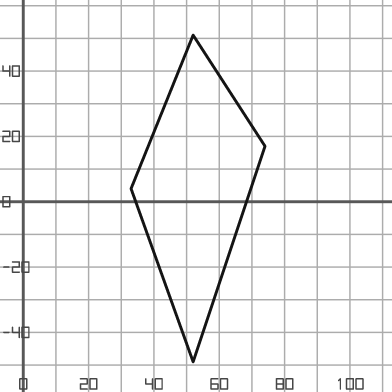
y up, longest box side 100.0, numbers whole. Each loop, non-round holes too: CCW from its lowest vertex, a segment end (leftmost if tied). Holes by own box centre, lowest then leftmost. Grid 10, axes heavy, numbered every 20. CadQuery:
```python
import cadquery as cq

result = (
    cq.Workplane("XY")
    .moveTo(52.0, -49.0)
    .lineTo(74.0, 17.0)
    .lineTo(52.0, 51.0)
    .lineTo(33.0, 4.0)
    .close()
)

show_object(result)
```